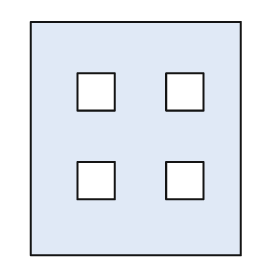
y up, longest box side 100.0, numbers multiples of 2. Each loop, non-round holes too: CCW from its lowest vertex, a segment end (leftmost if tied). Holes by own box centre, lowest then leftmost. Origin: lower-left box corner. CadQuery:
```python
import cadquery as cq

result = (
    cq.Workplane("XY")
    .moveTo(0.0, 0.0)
    .lineTo(90.0, 0.0)
    .lineTo(90.0, 100.0)
    .lineTo(0.0, 100.0)
    .close()
    .moveTo(20.0, 24.0)
    .lineTo(36.0, 24.0)
    .lineTo(36.0, 40.0)
    .lineTo(20.0, 40.0)
    .close()
    .moveTo(58.0, 24.0)
    .lineTo(74.0, 24.0)
    .lineTo(74.0, 40.0)
    .lineTo(58.0, 40.0)
    .close()
    .moveTo(20.0, 62.0)
    .lineTo(36.0, 62.0)
    .lineTo(36.0, 78.0)
    .lineTo(20.0, 78.0)
    .close()
    .moveTo(58.0, 62.0)
    .lineTo(74.0, 62.0)
    .lineTo(74.0, 78.0)
    .lineTo(58.0, 78.0)
    .close()
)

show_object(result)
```